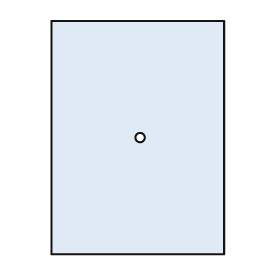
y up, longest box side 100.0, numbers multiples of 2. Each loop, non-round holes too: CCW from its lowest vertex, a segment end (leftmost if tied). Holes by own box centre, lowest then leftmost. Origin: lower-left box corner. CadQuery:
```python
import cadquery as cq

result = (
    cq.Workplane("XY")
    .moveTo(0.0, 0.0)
    .lineTo(74.0, 0.0)
    .lineTo(74.0, 100.0)
    .lineTo(0.0, 100.0)
    .close()
    .moveTo(38.0, 50.0)
    .circle(2.0)
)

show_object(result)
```